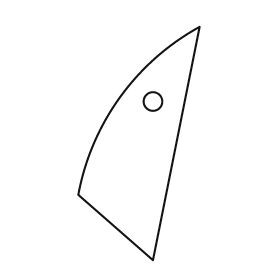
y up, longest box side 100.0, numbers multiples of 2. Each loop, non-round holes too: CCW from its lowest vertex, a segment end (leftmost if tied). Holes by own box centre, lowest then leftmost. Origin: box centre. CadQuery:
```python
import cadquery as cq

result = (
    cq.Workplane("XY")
    .moveTo(6.0, -50.0)
    .lineTo(26.0, 50.0)
    .threePointArc((-8.0, 20.0), (-26.0, -22.0))
    .close()
    .moveTo(6.0, 18.0)
    .circle(4.0)
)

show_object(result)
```